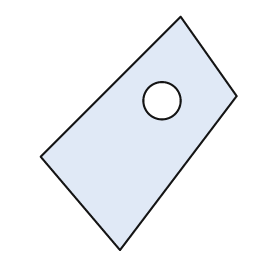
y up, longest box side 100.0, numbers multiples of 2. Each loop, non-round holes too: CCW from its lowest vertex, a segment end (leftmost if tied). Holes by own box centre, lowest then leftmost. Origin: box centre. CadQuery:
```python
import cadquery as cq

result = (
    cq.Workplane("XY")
    .moveTo(-8.0, -50.0)
    .lineTo(42.0, 16.0)
    .lineTo(18.0, 50.0)
    .lineTo(-42.0, -10.0)
    .close()
    .moveTo(10.0, 14.0)
    .circle(8.0)
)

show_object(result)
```